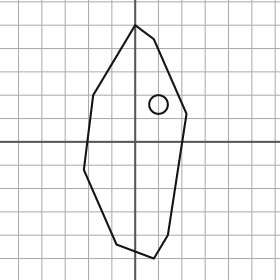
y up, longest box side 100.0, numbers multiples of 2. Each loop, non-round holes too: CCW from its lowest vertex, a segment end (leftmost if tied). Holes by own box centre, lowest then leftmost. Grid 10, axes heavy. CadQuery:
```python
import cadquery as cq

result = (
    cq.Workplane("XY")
    .moveTo(8.0, -50.0)
    .lineTo(14.0, -40.0)
    .lineTo(22.0, 12.0)
    .lineTo(8.0, 44.0)
    .lineTo(0.0, 50.0)
    .lineTo(-18.0, 20.0)
    .lineTo(-22.0, -12.0)
    .lineTo(-8.0, -44.0)
    .close()
    .moveTo(10.0, 16.0)
    .circle(4.0)
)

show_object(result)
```